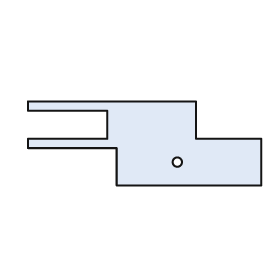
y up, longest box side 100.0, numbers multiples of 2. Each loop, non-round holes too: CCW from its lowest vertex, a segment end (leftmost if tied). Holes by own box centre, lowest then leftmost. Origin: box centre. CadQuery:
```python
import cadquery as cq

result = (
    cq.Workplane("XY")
    .moveTo(-12.0, -18.0)
    .lineTo(50.0, -18.0)
    .lineTo(50.0, 2.0)
    .lineTo(22.0, 2.0)
    .lineTo(22.0, 18.0)
    .lineTo(-50.0, 18.0)
    .lineTo(-50.0, 14.0)
    .lineTo(-16.0, 14.0)
    .lineTo(-16.0, 2.0)
    .lineTo(-50.0, 2.0)
    .lineTo(-50.0, -2.0)
    .lineTo(-12.0, -2.0)
    .close()
    .moveTo(14.0, -8.0)
    .circle(2.0)
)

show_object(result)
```